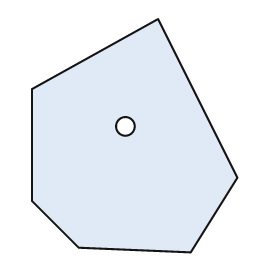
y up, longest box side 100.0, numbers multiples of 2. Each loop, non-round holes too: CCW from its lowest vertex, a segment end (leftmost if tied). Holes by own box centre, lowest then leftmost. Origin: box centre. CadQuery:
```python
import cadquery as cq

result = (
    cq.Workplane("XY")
    .moveTo(24.0, -50.0)
    .lineTo(44.0, -18.0)
    .lineTo(10.0, 50.0)
    .lineTo(-44.0, 20.0)
    .lineTo(-44.0, -28.0)
    .lineTo(-24.0, -48.0)
    .close()
    .moveTo(-4.0, 4.0)
    .circle(4.0)
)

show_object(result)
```